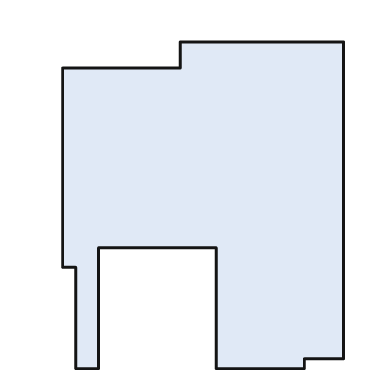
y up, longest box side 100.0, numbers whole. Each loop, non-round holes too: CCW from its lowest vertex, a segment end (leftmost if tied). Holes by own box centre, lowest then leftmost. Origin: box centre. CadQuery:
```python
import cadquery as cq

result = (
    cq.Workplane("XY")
    .moveTo(-39.0, -50.0)
    .lineTo(-32.0, -50.0)
    .lineTo(-32.0, -13.0)
    .lineTo(4.0, -13.0)
    .lineTo(4.0, -50.0)
    .lineTo(31.0, -50.0)
    .lineTo(31.0, -47.0)
    .lineTo(43.0, -47.0)
    .lineTo(43.0, 50.0)
    .lineTo(-7.0, 50.0)
    .lineTo(-7.0, 42.0)
    .lineTo(-43.0, 42.0)
    .lineTo(-43.0, -19.0)
    .lineTo(-39.0, -19.0)
    .close()
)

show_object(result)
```